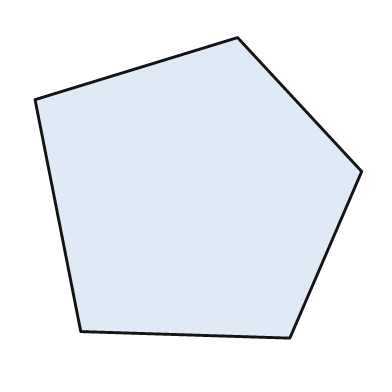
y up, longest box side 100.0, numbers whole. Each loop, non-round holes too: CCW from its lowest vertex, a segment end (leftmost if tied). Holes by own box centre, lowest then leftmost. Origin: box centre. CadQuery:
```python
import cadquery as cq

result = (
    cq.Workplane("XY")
    .moveTo(28.0, -46.0)
    .lineTo(50.0, 5.0)
    .lineTo(12.0, 46.0)
    .lineTo(-50.0, 27.0)
    .lineTo(-36.0, -44.0)
    .close()
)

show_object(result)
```